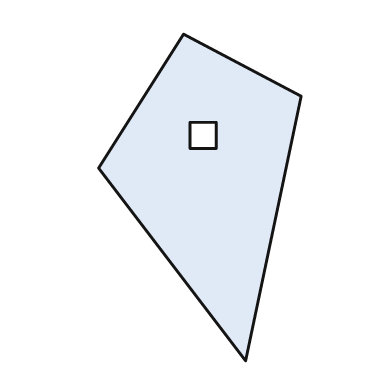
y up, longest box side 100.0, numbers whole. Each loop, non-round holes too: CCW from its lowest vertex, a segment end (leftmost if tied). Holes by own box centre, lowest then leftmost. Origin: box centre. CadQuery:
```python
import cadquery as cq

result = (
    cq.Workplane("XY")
    .moveTo(14.0, -50.0)
    .lineTo(31.0, 31.0)
    .lineTo(-5.0, 50.0)
    .lineTo(-31.0, 9.0)
    .close()
    .moveTo(-3.0, 15.0)
    .lineTo(5.0, 15.0)
    .lineTo(5.0, 23.0)
    .lineTo(-3.0, 23.0)
    .close()
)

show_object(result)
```